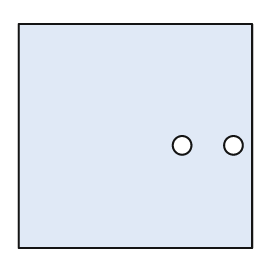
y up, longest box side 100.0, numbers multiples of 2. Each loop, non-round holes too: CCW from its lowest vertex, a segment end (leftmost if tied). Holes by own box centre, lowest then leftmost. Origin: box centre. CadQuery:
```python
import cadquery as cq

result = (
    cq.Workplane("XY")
    .moveTo(-50.0, -48.0)
    .lineTo(50.0, -48.0)
    .lineTo(50.0, 48.0)
    .lineTo(-50.0, 48.0)
    .close()
    .moveTo(20.0, -4.0)
    .circle(4.0)
    .moveTo(42.0, -4.0)
    .circle(4.0)
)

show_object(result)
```